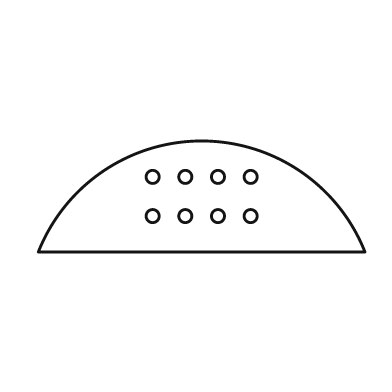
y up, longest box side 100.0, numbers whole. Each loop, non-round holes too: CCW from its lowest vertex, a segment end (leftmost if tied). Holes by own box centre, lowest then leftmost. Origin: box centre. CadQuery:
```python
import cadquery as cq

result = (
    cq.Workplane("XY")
    .moveTo(-50.0, -17.0)
    .lineTo(50.0, -17.0)
    .threePointArc((0.0, 17.0), (-50.0, -17.0))
    .close()
    .moveTo(-15.0, -6.0)
    .circle(2.0)
    .moveTo(-5.0, -6.0)
    .circle(2.0)
    .moveTo(5.0, -6.0)
    .circle(2.0)
    .moveTo(15.0, -6.0)
    .circle(2.0)
    .moveTo(-15.0, 6.0)
    .circle(2.0)
    .moveTo(-5.0, 6.0)
    .circle(2.0)
    .moveTo(5.0, 6.0)
    .circle(2.0)
    .moveTo(15.0, 6.0)
    .circle(2.0)
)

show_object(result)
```